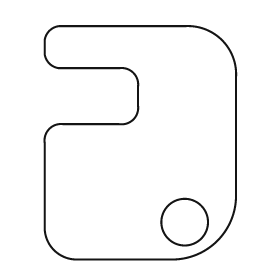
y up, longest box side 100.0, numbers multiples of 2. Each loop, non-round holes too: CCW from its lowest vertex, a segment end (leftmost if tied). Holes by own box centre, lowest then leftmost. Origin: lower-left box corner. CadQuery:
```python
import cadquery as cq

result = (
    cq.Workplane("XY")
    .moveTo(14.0, 0.0)
    .lineTo(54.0, 0.0)
    .threePointArc((74.0, 8.0), (82.0, 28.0))
    .lineTo(82.0, 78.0)
    .threePointArc((76.0, 94.0), (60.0, 100.0))
    .lineTo(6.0, 100.0)
    .threePointArc((2.0, 98.0), (0.0, 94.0))
    .lineTo(0.0, 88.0)
    .threePointArc((2.0, 84.0), (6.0, 82.0))
    .lineTo(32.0, 82.0)
    .threePointArc((38.0, 80.0), (40.0, 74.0))
    .lineTo(40.0, 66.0)
    .threePointArc((38.0, 60.0), (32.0, 58.0))
    .lineTo(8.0, 58.0)
    .threePointArc((2.0, 56.0), (0.0, 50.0))
    .lineTo(0.0, 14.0)
    .threePointArc((4.0, 4.0), (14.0, 0.0))
    .close()
    .moveTo(60.0, 16.0)
    .circle(10.0)
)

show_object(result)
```